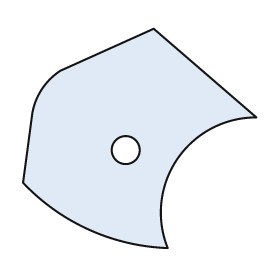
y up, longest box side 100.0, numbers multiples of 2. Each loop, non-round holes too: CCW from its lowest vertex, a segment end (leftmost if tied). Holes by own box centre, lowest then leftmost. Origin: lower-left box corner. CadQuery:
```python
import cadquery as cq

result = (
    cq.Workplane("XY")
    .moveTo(62.0, 0.0)
    .threePointArc((66.0, 38.0), (100.0, 56.0))
    .lineTo(56.0, 94.0)
    .lineTo(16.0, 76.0)
    .threePointArc((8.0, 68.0), (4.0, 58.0))
    .lineTo(0.0, 28.0)
    .threePointArc((28.0, 8.0), (62.0, 0.0))
    .close()
    .moveTo(44.0, 42.0)
    .circle(6.0)
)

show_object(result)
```